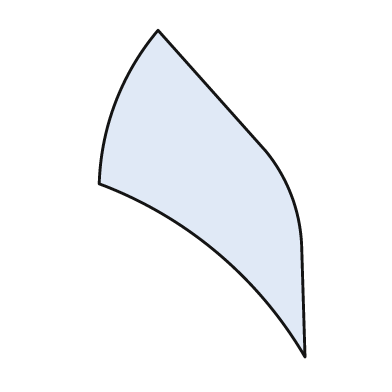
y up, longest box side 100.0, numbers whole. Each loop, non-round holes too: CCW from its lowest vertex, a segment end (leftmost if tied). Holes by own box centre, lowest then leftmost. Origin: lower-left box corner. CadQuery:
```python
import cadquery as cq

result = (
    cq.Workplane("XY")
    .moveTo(63.0, 0.0)
    .lineTo(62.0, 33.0)
    .threePointArc((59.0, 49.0), (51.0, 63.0))
    .lineTo(18.0, 100.0)
    .threePointArc((5.0, 78.0), (0.0, 53.0))
    .threePointArc((36.0, 32.0), (63.0, 0.0))
    .close()
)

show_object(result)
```